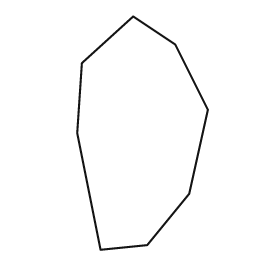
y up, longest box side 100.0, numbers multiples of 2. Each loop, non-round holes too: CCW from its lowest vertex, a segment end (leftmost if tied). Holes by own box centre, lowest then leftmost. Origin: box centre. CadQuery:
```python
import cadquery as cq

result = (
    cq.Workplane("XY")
    .moveTo(-18.0, -50.0)
    .lineTo(2.0, -48.0)
    .lineTo(20.0, -26.0)
    .lineTo(28.0, 10.0)
    .lineTo(14.0, 38.0)
    .lineTo(-4.0, 50.0)
    .lineTo(-26.0, 30.0)
    .lineTo(-28.0, 0.0)
    .close()
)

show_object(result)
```